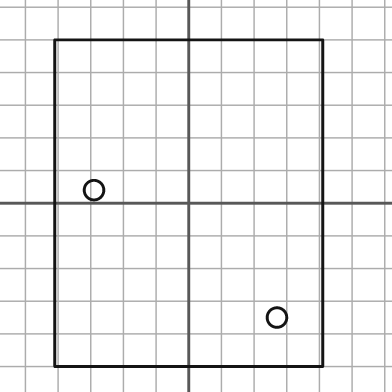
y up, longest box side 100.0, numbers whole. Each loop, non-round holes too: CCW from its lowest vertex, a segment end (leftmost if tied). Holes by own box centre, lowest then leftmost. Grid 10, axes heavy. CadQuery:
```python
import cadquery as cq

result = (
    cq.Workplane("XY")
    .moveTo(-41.0, -50.0)
    .lineTo(41.0, -50.0)
    .lineTo(41.0, 50.0)
    .lineTo(-41.0, 50.0)
    .close()
    .moveTo(27.0, -35.0)
    .circle(3.0)
    .moveTo(-29.0, 4.0)
    .circle(3.0)
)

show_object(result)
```